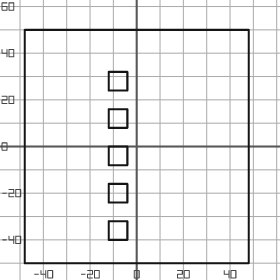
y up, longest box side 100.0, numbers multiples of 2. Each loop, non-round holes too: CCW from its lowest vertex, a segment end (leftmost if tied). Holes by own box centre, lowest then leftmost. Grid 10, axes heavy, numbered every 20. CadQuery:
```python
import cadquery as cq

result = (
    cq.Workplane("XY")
    .moveTo(-48.0, -50.0)
    .lineTo(48.0, -50.0)
    .lineTo(48.0, 50.0)
    .lineTo(-48.0, 50.0)
    .close()
    .moveTo(-12.0, -40.0)
    .lineTo(-4.0, -40.0)
    .lineTo(-4.0, -32.0)
    .lineTo(-12.0, -32.0)
    .close()
    .moveTo(-12.0, -24.0)
    .lineTo(-4.0, -24.0)
    .lineTo(-4.0, -16.0)
    .lineTo(-12.0, -16.0)
    .close()
    .moveTo(-12.0, -8.0)
    .lineTo(-4.0, -8.0)
    .lineTo(-4.0, 0.0)
    .lineTo(-12.0, 0.0)
    .close()
    .moveTo(-12.0, 8.0)
    .lineTo(-4.0, 8.0)
    .lineTo(-4.0, 16.0)
    .lineTo(-12.0, 16.0)
    .close()
    .moveTo(-12.0, 24.0)
    .lineTo(-4.0, 24.0)
    .lineTo(-4.0, 32.0)
    .lineTo(-12.0, 32.0)
    .close()
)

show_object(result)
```